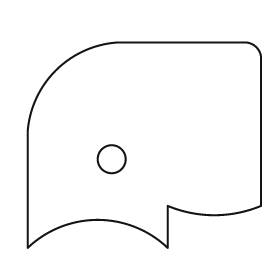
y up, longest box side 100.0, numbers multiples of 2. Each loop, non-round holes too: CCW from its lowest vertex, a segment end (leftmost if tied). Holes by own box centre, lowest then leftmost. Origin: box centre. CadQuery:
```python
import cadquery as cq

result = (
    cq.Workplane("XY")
    .moveTo(-50.0, -44.0)
    .threePointArc((-20.0, -32.0), (10.0, -44.0))
    .lineTo(10.0, -26.0)
    .threePointArc((30.0, -30.0), (50.0, -26.0))
    .lineTo(50.0, 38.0)
    .threePointArc((48.0, 42.0), (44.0, 44.0))
    .lineTo(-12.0, 44.0)
    .threePointArc((-38.0, 32.0), (-50.0, 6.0))
    .close()
    .moveTo(-14.0, -6.0)
    .circle(6.0)
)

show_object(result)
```